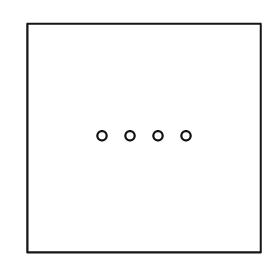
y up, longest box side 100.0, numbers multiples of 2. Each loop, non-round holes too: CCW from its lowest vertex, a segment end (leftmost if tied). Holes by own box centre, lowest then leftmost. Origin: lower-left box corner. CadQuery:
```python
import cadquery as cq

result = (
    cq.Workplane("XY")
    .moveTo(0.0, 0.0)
    .lineTo(100.0, 0.0)
    .lineTo(100.0, 98.0)
    .lineTo(0.0, 98.0)
    .close()
    .moveTo(32.0, 50.0)
    .circle(2.0)
    .moveTo(44.0, 50.0)
    .circle(2.0)
    .moveTo(56.0, 50.0)
    .circle(2.0)
    .moveTo(68.0, 50.0)
    .circle(2.0)
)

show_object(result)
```